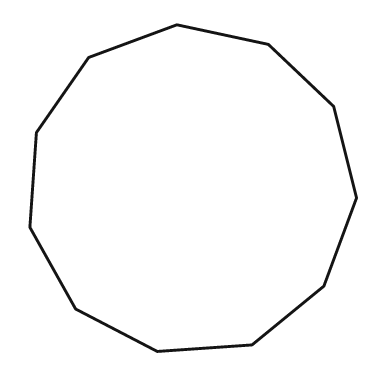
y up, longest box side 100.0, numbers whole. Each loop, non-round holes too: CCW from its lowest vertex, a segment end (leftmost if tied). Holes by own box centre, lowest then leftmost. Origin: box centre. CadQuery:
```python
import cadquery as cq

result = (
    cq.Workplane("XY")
    .moveTo(-11.0, -50.0)
    .lineTo(18.0, -48.0)
    .lineTo(40.0, -30.0)
    .lineTo(50.0, -3.0)
    .lineTo(43.0, 25.0)
    .lineTo(23.0, 44.0)
    .lineTo(-5.0, 50.0)
    .lineTo(-32.0, 40.0)
    .lineTo(-48.0, 17.0)
    .lineTo(-50.0, -12.0)
    .lineTo(-36.0, -37.0)
    .close()
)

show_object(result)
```